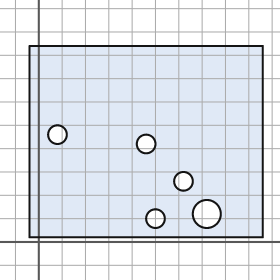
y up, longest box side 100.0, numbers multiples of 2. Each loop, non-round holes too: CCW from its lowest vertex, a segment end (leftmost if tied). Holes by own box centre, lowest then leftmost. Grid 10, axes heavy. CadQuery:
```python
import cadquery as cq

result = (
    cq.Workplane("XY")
    .moveTo(-4.0, 2.0)
    .lineTo(96.0, 2.0)
    .lineTo(96.0, 84.0)
    .lineTo(-4.0, 84.0)
    .close()
    .moveTo(50.0, 10.0)
    .circle(4.0)
    .moveTo(72.0, 12.0)
    .circle(6.0)
    .moveTo(62.0, 26.0)
    .circle(4.0)
    .moveTo(46.0, 42.0)
    .circle(4.0)
    .moveTo(8.0, 46.0)
    .circle(4.0)
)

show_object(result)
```